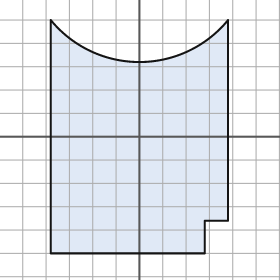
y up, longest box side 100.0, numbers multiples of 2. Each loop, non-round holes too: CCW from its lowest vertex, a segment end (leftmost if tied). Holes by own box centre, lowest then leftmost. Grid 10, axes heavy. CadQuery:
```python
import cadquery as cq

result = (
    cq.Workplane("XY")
    .moveTo(-38.0, -50.0)
    .lineTo(28.0, -50.0)
    .lineTo(28.0, -36.0)
    .lineTo(38.0, -36.0)
    .lineTo(38.0, 50.0)
    .threePointArc((0.0, 32.0), (-38.0, 50.0))
    .close()
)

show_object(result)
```